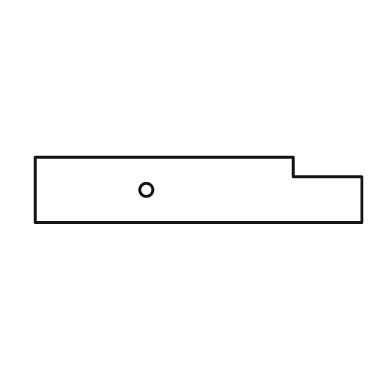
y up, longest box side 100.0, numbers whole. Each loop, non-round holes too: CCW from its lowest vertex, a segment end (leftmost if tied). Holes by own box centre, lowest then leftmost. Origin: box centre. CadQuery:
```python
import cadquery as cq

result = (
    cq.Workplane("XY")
    .moveTo(-50.0, -10.0)
    .lineTo(50.0, -10.0)
    .lineTo(50.0, 4.0)
    .lineTo(29.0, 4.0)
    .lineTo(29.0, 10.0)
    .lineTo(-50.0, 10.0)
    .close()
    .moveTo(-16.0, 0.0)
    .circle(2.0)
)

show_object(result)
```